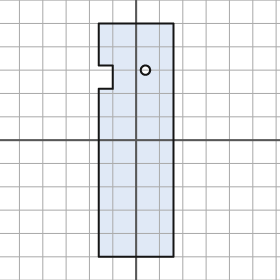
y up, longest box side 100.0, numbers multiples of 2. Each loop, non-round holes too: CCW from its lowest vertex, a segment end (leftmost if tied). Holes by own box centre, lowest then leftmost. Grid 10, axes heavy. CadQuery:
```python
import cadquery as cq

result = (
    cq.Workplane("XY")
    .moveTo(-16.0, -50.0)
    .lineTo(16.0, -50.0)
    .lineTo(16.0, 50.0)
    .lineTo(-16.0, 50.0)
    .lineTo(-16.0, 32.0)
    .lineTo(-10.0, 32.0)
    .lineTo(-10.0, 22.0)
    .lineTo(-16.0, 22.0)
    .close()
    .moveTo(4.0, 30.0)
    .circle(2.0)
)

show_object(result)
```